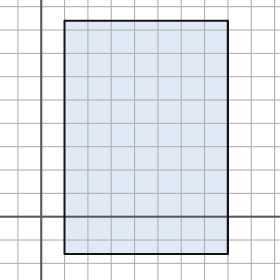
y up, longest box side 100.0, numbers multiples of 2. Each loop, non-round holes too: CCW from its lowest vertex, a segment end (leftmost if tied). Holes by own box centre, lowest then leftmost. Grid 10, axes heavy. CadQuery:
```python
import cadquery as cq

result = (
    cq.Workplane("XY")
    .moveTo(10.0, -16.0)
    .lineTo(80.0, -16.0)
    .lineTo(80.0, 84.0)
    .lineTo(10.0, 84.0)
    .close()
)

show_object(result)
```